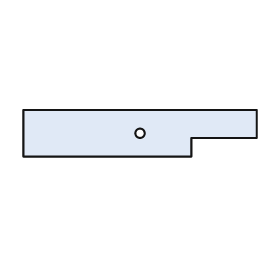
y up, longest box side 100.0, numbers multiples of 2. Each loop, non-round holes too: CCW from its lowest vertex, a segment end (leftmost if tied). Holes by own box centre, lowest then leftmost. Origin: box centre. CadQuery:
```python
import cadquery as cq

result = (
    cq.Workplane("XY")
    .moveTo(-50.0, -10.0)
    .lineTo(22.0, -10.0)
    .lineTo(22.0, -2.0)
    .lineTo(50.0, -2.0)
    .lineTo(50.0, 10.0)
    .lineTo(-50.0, 10.0)
    .close()
    .moveTo(0.0, 0.0)
    .circle(2.0)
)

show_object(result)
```